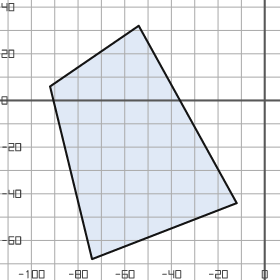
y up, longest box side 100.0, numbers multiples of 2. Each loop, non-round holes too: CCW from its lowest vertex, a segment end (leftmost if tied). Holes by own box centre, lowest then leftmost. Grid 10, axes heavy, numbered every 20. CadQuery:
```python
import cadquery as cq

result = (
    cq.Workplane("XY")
    .moveTo(-74.0, -68.0)
    .lineTo(-12.0, -44.0)
    .lineTo(-54.0, 32.0)
    .lineTo(-92.0, 6.0)
    .close()
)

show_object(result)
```